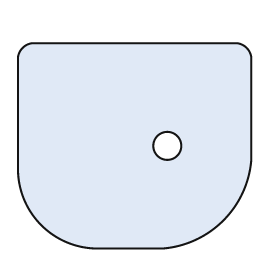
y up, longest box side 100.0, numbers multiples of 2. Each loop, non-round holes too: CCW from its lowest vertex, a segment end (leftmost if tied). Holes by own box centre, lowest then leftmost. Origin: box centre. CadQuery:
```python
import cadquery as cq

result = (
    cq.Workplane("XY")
    .moveTo(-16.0, -44.0)
    .lineTo(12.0, -44.0)
    .threePointArc((38.0, -32.0), (50.0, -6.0))
    .lineTo(50.0, 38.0)
    .threePointArc((48.0, 42.0), (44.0, 44.0))
    .lineTo(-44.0, 44.0)
    .threePointArc((-48.0, 42.0), (-50.0, 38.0))
    .lineTo(-50.0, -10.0)
    .threePointArc((-40.0, -34.0), (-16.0, -44.0))
    .close()
    .moveTo(14.0, 0.0)
    .circle(6.0)
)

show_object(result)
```